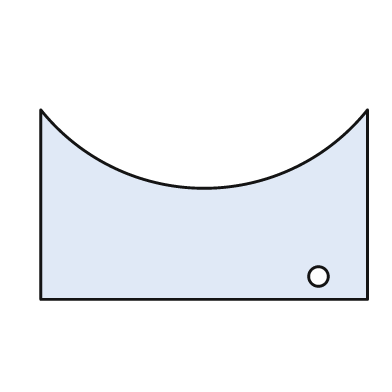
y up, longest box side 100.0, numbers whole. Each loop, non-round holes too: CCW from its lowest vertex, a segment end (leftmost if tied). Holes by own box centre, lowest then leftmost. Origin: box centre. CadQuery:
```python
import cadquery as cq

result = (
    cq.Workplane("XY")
    .moveTo(-50.0, -29.0)
    .lineTo(50.0, -29.0)
    .lineTo(50.0, 29.0)
    .threePointArc((0.0, 5.0), (-50.0, 29.0))
    .close()
    .moveTo(35.0, -22.0)
    .circle(3.0)
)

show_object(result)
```